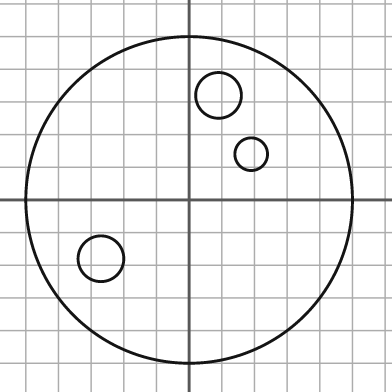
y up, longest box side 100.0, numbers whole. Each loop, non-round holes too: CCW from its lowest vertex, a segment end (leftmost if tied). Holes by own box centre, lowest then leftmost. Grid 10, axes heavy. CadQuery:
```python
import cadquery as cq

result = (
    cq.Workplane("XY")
    .moveTo(0.0, 0.0)
    .circle(50.0)
    .moveTo(-27.0, -18.0)
    .circle(7.0)
    .moveTo(19.0, 14.0)
    .circle(5.0)
    .moveTo(9.0, 32.0)
    .circle(7.0)
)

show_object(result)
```